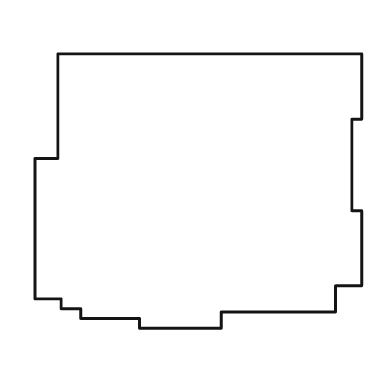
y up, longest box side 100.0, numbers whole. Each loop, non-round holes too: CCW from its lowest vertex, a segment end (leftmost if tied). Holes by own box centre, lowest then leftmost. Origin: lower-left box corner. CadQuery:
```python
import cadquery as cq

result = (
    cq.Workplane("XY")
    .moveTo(32.0, 0.0)
    .lineTo(57.0, 0.0)
    .lineTo(57.0, 5.0)
    .lineTo(92.0, 5.0)
    .lineTo(92.0, 13.0)
    .lineTo(100.0, 13.0)
    .lineTo(100.0, 36.0)
    .lineTo(97.0, 36.0)
    .lineTo(97.0, 64.0)
    .lineTo(100.0, 64.0)
    .lineTo(100.0, 84.0)
    .lineTo(7.0, 84.0)
    .lineTo(7.0, 52.0)
    .lineTo(0.0, 52.0)
    .lineTo(0.0, 9.0)
    .lineTo(8.0, 9.0)
    .lineTo(8.0, 6.0)
    .lineTo(14.0, 6.0)
    .lineTo(14.0, 3.0)
    .lineTo(32.0, 3.0)
    .close()
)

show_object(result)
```